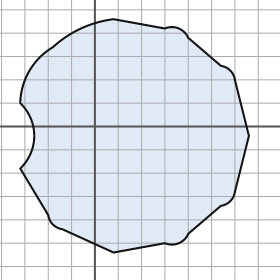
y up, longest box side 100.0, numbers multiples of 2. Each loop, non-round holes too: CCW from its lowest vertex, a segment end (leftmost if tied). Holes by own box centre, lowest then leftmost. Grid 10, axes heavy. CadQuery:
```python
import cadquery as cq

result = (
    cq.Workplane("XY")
    .moveTo(8.0, -54.0)
    .lineTo(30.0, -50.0)
    .threePointArc((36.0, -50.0), (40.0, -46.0))
    .lineTo(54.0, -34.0)
    .threePointArc((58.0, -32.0), (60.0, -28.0))
    .lineTo(66.0, -4.0)
    .lineTo(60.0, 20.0)
    .threePointArc((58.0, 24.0), (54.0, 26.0))
    .lineTo(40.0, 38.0)
    .threePointArc((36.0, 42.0), (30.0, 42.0))
    .lineTo(8.0, 46.0)
    .threePointArc((-6.0, 42.0), (-18.0, 34.0))
    .threePointArc((-28.0, 24.0), (-32.0, 10.0))
    .threePointArc((-26.0, -4.0), (-32.0, -18.0))
    .lineTo(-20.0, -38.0)
    .threePointArc((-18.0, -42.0), (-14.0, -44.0))
    .close()
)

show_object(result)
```